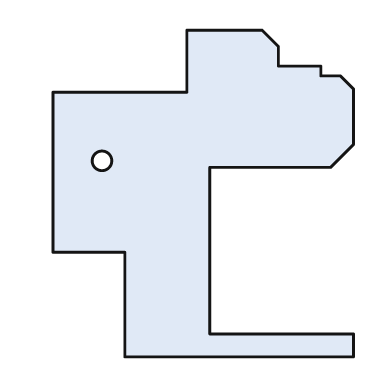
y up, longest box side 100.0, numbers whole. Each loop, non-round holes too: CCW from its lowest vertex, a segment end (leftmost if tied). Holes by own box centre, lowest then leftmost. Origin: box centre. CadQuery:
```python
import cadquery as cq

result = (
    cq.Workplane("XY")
    .moveTo(-24.0, -50.0)
    .lineTo(46.0, -50.0)
    .lineTo(46.0, -43.0)
    .lineTo(2.0, -43.0)
    .lineTo(2.0, 8.0)
    .lineTo(39.0, 8.0)
    .lineTo(46.0, 15.0)
    .lineTo(46.0, 32.0)
    .lineTo(42.0, 36.0)
    .lineTo(36.0, 36.0)
    .lineTo(36.0, 39.0)
    .lineTo(23.0, 39.0)
    .lineTo(23.0, 45.0)
    .lineTo(18.0, 50.0)
    .lineTo(-5.0, 50.0)
    .lineTo(-5.0, 31.0)
    .lineTo(-46.0, 31.0)
    .lineTo(-46.0, -18.0)
    .lineTo(-24.0, -18.0)
    .close()
    .moveTo(-31.0, 10.0)
    .circle(3.0)
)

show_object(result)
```